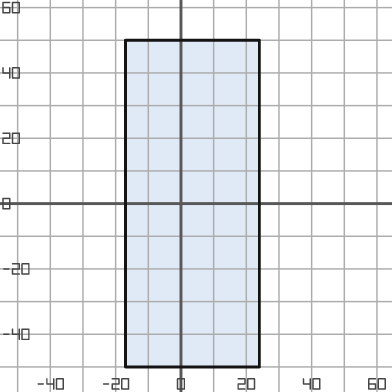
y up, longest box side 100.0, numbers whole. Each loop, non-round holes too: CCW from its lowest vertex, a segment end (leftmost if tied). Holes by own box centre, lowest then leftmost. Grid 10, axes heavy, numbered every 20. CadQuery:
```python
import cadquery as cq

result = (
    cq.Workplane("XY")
    .moveTo(-17.0, -50.0)
    .lineTo(24.0, -50.0)
    .lineTo(24.0, 50.0)
    .lineTo(-17.0, 50.0)
    .close()
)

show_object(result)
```